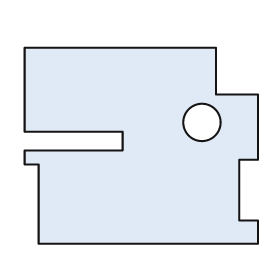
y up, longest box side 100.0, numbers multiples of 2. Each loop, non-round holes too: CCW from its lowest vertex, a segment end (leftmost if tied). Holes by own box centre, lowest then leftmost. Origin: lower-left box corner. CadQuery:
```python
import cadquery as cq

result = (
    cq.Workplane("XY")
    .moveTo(6.0, 0.0)
    .lineTo(100.0, 0.0)
    .lineTo(100.0, 10.0)
    .lineTo(92.0, 10.0)
    .lineTo(92.0, 36.0)
    .lineTo(100.0, 36.0)
    .lineTo(100.0, 64.0)
    .lineTo(82.0, 64.0)
    .lineTo(82.0, 84.0)
    .lineTo(0.0, 84.0)
    .lineTo(0.0, 48.0)
    .lineTo(42.0, 48.0)
    .lineTo(42.0, 40.0)
    .lineTo(0.0, 40.0)
    .lineTo(0.0, 34.0)
    .lineTo(6.0, 34.0)
    .close()
    .moveTo(76.0, 52.0)
    .circle(8.0)
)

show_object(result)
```